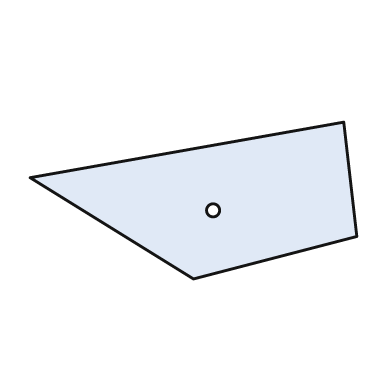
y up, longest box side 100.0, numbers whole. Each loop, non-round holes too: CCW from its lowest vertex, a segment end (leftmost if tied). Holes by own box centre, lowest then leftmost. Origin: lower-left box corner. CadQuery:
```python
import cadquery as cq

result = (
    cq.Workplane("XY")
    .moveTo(50.0, 0.0)
    .lineTo(100.0, 13.0)
    .lineTo(96.0, 48.0)
    .lineTo(0.0, 31.0)
    .close()
    .moveTo(56.0, 21.0)
    .circle(2.0)
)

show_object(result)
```